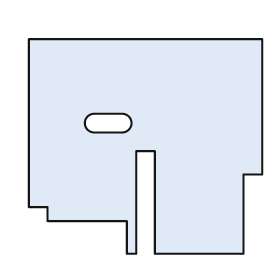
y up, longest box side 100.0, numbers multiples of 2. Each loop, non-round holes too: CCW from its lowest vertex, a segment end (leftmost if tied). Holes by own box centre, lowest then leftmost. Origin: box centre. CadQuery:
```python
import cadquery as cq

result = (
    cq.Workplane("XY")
    .moveTo(-8.0, -46.0)
    .lineTo(-4.0, -46.0)
    .lineTo(-4.0, -2.0)
    .lineTo(4.0, -2.0)
    .lineTo(4.0, -46.0)
    .lineTo(42.0, -46.0)
    .lineTo(42.0, -12.0)
    .lineTo(50.0, -12.0)
    .lineTo(50.0, 46.0)
    .lineTo(-50.0, 46.0)
    .lineTo(-50.0, -26.0)
    .lineTo(-42.0, -26.0)
    .lineTo(-42.0, -32.0)
    .lineTo(-8.0, -32.0)
    .close()
    .moveTo(-22.0, 6.0)
    .lineTo(-10.0, 6.0)
    .threePointArc((-6.0, 10.0), (-10.0, 14.0))
    .lineTo(-22.0, 14.0)
    .threePointArc((-26.0, 10.0), (-22.0, 6.0))
    .close()
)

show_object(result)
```